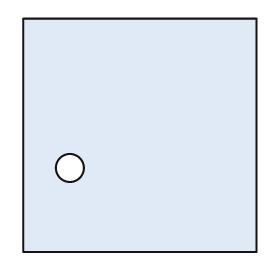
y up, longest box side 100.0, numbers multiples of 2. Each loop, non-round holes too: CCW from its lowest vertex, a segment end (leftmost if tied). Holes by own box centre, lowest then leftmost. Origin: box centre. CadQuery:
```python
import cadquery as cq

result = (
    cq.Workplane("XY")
    .moveTo(-50.0, -50.0)
    .lineTo(50.0, -50.0)
    .lineTo(50.0, 50.0)
    .lineTo(-50.0, 50.0)
    .close()
    .moveTo(-30.0, -14.0)
    .circle(6.0)
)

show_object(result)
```